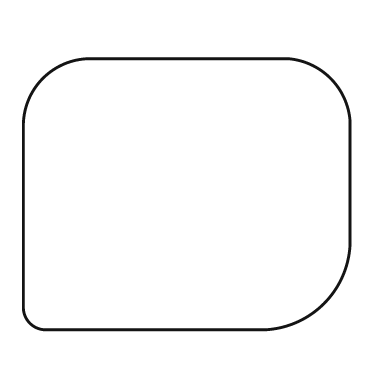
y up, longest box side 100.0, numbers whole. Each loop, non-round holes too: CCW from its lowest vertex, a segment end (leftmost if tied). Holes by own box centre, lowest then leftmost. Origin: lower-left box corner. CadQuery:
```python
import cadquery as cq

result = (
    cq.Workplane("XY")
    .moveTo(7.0, 0.0)
    .lineTo(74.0, 0.0)
    .threePointArc((92.0, 8.0), (100.0, 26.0))
    .lineTo(100.0, 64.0)
    .threePointArc((94.0, 77.0), (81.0, 83.0))
    .lineTo(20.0, 83.0)
    .threePointArc((6.0, 77.0), (0.0, 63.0))
    .lineTo(0.0, 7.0)
    .threePointArc((2.0, 2.0), (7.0, 0.0))
    .close()
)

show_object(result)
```